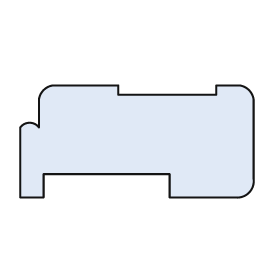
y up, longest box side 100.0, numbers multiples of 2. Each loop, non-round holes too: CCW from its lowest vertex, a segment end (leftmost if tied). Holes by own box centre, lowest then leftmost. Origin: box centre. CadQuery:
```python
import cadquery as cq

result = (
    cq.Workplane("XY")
    .moveTo(-50.0, -24.0)
    .lineTo(-40.0, -24.0)
    .lineTo(-40.0, -14.0)
    .lineTo(14.0, -14.0)
    .lineTo(14.0, -24.0)
    .lineTo(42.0, -24.0)
    .threePointArc((48.0, -22.0), (50.0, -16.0))
    .lineTo(50.0, 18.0)
    .threePointArc((48.0, 22.0), (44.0, 24.0))
    .lineTo(34.0, 24.0)
    .lineTo(34.0, 20.0)
    .lineTo(-8.0, 20.0)
    .lineTo(-8.0, 24.0)
    .lineTo(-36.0, 24.0)
    .threePointArc((-40.0, 22.0), (-42.0, 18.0))
    .lineTo(-42.0, 6.0)
    .threePointArc((-46.0, 8.0), (-50.0, 6.0))
    .close()
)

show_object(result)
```